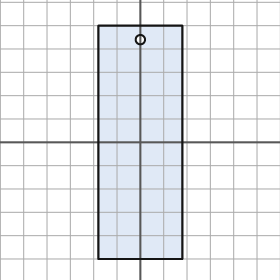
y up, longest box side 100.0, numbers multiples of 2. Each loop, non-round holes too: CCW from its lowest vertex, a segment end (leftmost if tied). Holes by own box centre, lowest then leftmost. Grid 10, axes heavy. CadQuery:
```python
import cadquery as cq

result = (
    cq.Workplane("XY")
    .moveTo(-18.0, -50.0)
    .lineTo(18.0, -50.0)
    .lineTo(18.0, 50.0)
    .lineTo(-18.0, 50.0)
    .close()
    .moveTo(0.0, 44.0)
    .circle(2.0)
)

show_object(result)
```